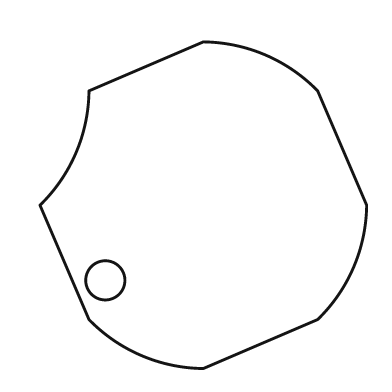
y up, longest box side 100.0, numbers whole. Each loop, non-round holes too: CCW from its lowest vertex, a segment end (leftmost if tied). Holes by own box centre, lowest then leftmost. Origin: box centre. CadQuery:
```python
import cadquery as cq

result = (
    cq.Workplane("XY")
    .moveTo(0.0, -50.0)
    .lineTo(35.0, -35.0)
    .threePointArc((46.0, -19.0), (50.0, 0.0))
    .lineTo(35.0, 35.0)
    .threePointArc((19.0, 46.0), (0.0, 50.0))
    .lineTo(-35.0, 35.0)
    .threePointArc((-39.0, 16.0), (-50.0, 0.0))
    .lineTo(-35.0, -35.0)
    .threePointArc((-19.0, -46.0), (0.0, -50.0))
    .close()
    .moveTo(-30.0, -23.0)
    .circle(6.0)
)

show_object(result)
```